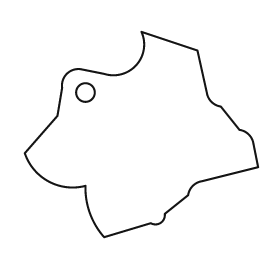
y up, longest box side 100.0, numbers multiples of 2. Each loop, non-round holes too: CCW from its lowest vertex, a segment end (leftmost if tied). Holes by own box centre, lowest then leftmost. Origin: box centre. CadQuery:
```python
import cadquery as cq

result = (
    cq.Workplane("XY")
    .moveTo(-16.0, -44.0)
    .lineTo(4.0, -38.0)
    .threePointArc((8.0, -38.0), (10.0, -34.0))
    .lineTo(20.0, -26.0)
    .threePointArc((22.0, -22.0), (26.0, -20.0))
    .lineTo(50.0, -14.0)
    .lineTo(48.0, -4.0)
    .threePointArc((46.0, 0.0), (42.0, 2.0))
    .lineTo(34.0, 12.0)
    .threePointArc((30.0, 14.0), (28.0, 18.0))
    .lineTo(24.0, 36.0)
    .lineTo(0.0, 44.0)
    .threePointArc((-2.0, 30.0), (-16.0, 26.0))
    .lineTo(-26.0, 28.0)
    .threePointArc((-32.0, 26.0), (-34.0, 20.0))
    .lineTo(-36.0, 8.0)
    .lineTo(-50.0, -8.0)
    .threePointArc((-40.0, -20.0), (-24.0, -22.0))
    .threePointArc((-22.0, -34.0), (-16.0, -44.0))
    .close()
    .moveTo(-24.0, 18.0)
    .circle(4.0)
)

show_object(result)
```